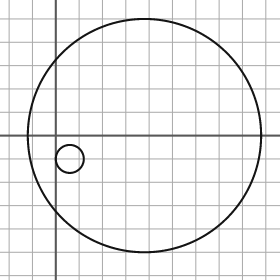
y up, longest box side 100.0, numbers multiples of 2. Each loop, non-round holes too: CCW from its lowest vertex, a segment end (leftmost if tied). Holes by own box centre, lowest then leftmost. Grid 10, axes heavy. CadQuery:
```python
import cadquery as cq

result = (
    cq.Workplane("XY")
    .moveTo(38.0, 0.0)
    .circle(50.0)
    .moveTo(6.0, -10.0)
    .circle(6.0)
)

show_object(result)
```